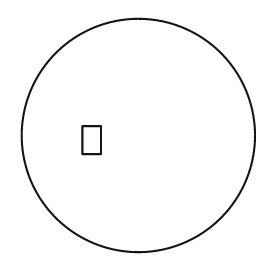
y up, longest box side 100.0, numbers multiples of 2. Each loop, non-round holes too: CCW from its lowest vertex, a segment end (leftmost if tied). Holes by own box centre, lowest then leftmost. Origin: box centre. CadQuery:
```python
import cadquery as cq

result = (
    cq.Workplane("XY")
    .moveTo(0.0, 0.0)
    .circle(50.0)
    .moveTo(-24.0, -8.0)
    .lineTo(-16.0, -8.0)
    .lineTo(-16.0, 4.0)
    .lineTo(-24.0, 4.0)
    .close()
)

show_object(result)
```